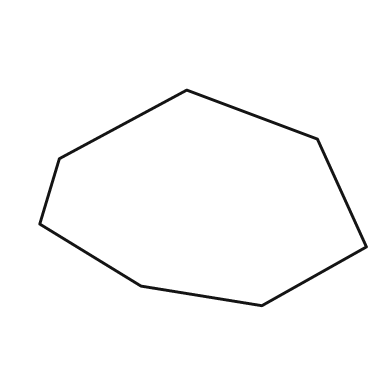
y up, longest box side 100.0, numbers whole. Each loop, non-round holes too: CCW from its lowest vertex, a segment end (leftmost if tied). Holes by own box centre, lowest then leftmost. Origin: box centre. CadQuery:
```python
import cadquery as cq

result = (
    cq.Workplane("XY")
    .moveTo(18.0, -33.0)
    .lineTo(50.0, -15.0)
    .lineTo(35.0, 18.0)
    .lineTo(-5.0, 33.0)
    .lineTo(-44.0, 12.0)
    .lineTo(-50.0, -8.0)
    .lineTo(-19.0, -27.0)
    .close()
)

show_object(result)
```